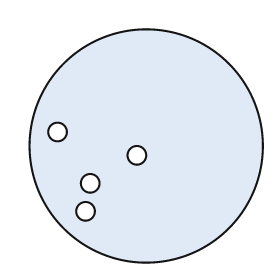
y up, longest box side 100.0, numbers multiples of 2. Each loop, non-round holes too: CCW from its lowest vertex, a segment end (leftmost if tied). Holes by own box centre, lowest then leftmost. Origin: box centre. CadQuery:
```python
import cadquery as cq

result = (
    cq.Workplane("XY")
    .moveTo(0.0, 0.0)
    .circle(50.0)
    .moveTo(-26.0, -28.0)
    .circle(4.0)
    .moveTo(-24.0, -16.0)
    .circle(4.0)
    .moveTo(-4.0, -4.0)
    .circle(4.0)
    .moveTo(-38.0, 6.0)
    .circle(4.0)
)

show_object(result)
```